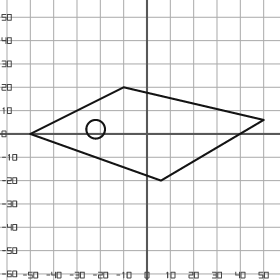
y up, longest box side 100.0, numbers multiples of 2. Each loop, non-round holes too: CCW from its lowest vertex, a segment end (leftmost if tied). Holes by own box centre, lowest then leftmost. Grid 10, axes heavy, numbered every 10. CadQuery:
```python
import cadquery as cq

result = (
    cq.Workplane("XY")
    .moveTo(6.0, -20.0)
    .lineTo(50.0, 6.0)
    .lineTo(-10.0, 20.0)
    .lineTo(-50.0, 0.0)
    .close()
    .moveTo(-22.0, 2.0)
    .circle(4.0)
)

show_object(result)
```